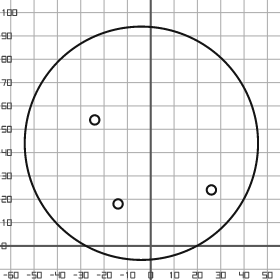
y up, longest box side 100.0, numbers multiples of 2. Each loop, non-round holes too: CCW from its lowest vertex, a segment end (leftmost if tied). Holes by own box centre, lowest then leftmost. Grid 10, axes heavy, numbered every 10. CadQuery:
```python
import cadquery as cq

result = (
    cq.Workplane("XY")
    .moveTo(-4.0, 44.0)
    .circle(50.0)
    .moveTo(-14.0, 18.0)
    .circle(2.0)
    .moveTo(26.0, 24.0)
    .circle(2.0)
    .moveTo(-24.0, 54.0)
    .circle(2.0)
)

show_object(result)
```